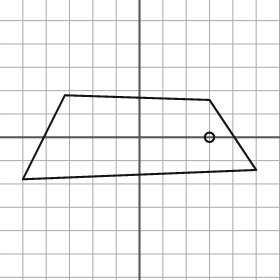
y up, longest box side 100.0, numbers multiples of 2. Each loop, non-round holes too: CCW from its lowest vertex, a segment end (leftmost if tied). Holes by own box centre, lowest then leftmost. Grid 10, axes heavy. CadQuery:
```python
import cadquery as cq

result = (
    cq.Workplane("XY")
    .moveTo(-50.0, -18.0)
    .lineTo(50.0, -14.0)
    .lineTo(30.0, 16.0)
    .lineTo(-32.0, 18.0)
    .close()
    .moveTo(30.0, 0.0)
    .circle(2.0)
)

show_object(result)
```